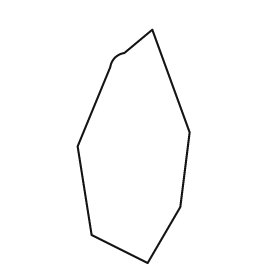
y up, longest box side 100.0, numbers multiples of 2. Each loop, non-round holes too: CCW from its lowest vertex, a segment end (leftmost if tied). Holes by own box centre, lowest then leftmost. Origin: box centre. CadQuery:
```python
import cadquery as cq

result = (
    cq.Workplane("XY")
    .moveTo(6.0, -50.0)
    .lineTo(20.0, -26.0)
    .lineTo(24.0, 6.0)
    .lineTo(8.0, 50.0)
    .lineTo(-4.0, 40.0)
    .threePointArc((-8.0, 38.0), (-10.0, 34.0))
    .lineTo(-24.0, 0.0)
    .lineTo(-18.0, -38.0)
    .close()
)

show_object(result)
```